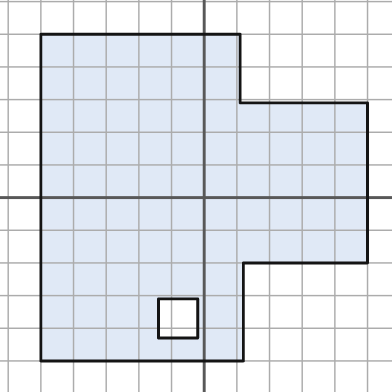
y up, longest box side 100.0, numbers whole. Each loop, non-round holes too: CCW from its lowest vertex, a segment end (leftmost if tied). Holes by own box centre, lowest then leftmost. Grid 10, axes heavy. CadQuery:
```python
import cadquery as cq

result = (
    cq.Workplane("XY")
    .moveTo(-50.0, -50.0)
    .lineTo(12.0, -50.0)
    .lineTo(12.0, -20.0)
    .lineTo(50.0, -20.0)
    .lineTo(50.0, 29.0)
    .lineTo(11.0, 29.0)
    .lineTo(11.0, 50.0)
    .lineTo(-50.0, 50.0)
    .close()
    .moveTo(-14.0, -43.0)
    .lineTo(-2.0, -43.0)
    .lineTo(-2.0, -31.0)
    .lineTo(-14.0, -31.0)
    .close()
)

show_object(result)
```